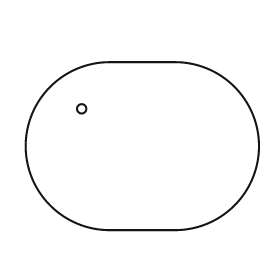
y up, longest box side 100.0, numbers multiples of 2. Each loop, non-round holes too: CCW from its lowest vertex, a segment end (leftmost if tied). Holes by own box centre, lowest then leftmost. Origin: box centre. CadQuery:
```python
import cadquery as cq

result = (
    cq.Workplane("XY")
    .moveTo(-14.0, -36.0)
    .lineTo(14.0, -36.0)
    .threePointArc((50.0, 0.0), (14.0, 36.0))
    .lineTo(-14.0, 36.0)
    .threePointArc((-50.0, 0.0), (-14.0, -36.0))
    .close()
    .moveTo(-26.0, 16.0)
    .circle(2.0)
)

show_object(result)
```